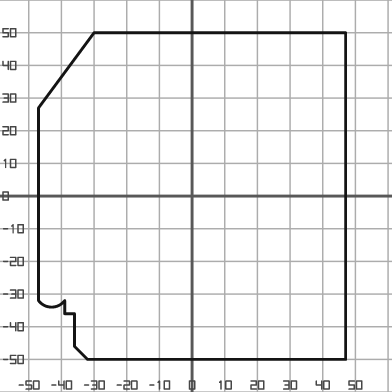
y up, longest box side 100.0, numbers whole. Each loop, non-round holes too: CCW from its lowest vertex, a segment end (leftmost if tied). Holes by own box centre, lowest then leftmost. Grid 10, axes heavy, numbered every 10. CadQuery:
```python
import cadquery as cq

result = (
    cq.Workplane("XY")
    .moveTo(-32.0, -50.0)
    .lineTo(47.0, -50.0)
    .lineTo(47.0, 50.0)
    .lineTo(-30.0, 50.0)
    .lineTo(-47.0, 27.0)
    .lineTo(-47.0, -32.0)
    .threePointArc((-43.0, -34.0), (-39.0, -32.0))
    .lineTo(-39.0, -36.0)
    .lineTo(-36.0, -36.0)
    .lineTo(-36.0, -46.0)
    .close()
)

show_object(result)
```